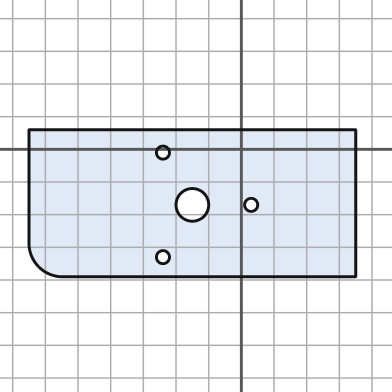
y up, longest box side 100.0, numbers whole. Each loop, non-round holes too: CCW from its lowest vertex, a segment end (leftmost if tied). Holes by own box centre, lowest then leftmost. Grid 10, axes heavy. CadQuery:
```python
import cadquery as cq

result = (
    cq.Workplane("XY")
    .moveTo(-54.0, -39.0)
    .lineTo(35.0, -39.0)
    .lineTo(35.0, 6.0)
    .lineTo(-65.0, 6.0)
    .lineTo(-65.0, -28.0)
    .threePointArc((-62.0, -36.0), (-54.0, -39.0))
    .close()
    .moveTo(-24.0, -33.0)
    .circle(2.0)
    .moveTo(-15.0, -17.0)
    .circle(5.0)
    .moveTo(3.0, -17.0)
    .circle(2.0)
    .moveTo(-24.0, -1.0)
    .circle(2.0)
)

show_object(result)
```